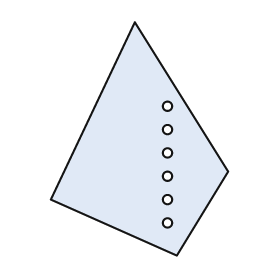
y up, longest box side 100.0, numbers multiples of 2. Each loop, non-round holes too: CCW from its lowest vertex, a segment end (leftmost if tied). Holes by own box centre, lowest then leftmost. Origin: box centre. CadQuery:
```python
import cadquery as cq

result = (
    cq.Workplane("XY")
    .moveTo(16.0, -50.0)
    .lineTo(38.0, -14.0)
    .lineTo(-2.0, 50.0)
    .lineTo(-38.0, -26.0)
    .close()
    .moveTo(12.0, -36.0)
    .circle(2.0)
    .moveTo(12.0, -26.0)
    .circle(2.0)
    .moveTo(12.0, -16.0)
    .circle(2.0)
    .moveTo(12.0, -6.0)
    .circle(2.0)
    .moveTo(12.0, 4.0)
    .circle(2.0)
    .moveTo(12.0, 14.0)
    .circle(2.0)
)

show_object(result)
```